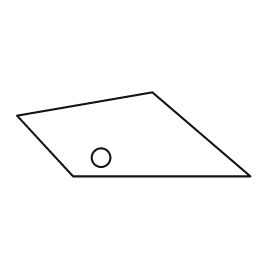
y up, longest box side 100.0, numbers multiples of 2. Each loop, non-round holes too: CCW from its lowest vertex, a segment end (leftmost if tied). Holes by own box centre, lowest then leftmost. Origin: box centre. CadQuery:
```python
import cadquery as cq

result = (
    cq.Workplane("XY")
    .moveTo(-26.0, -18.0)
    .lineTo(50.0, -18.0)
    .lineTo(8.0, 18.0)
    .lineTo(-50.0, 8.0)
    .close()
    .moveTo(-14.0, -10.0)
    .circle(4.0)
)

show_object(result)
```